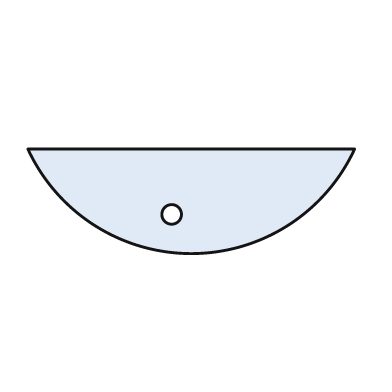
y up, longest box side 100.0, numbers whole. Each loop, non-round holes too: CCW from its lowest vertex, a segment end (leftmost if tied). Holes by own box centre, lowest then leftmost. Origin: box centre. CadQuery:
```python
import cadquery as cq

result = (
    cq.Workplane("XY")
    .moveTo(-50.0, 16.0)
    .threePointArc((0.0, -16.0), (50.0, 16.0))
    .close()
    .moveTo(-6.0, -4.0)
    .circle(3.0)
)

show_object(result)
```